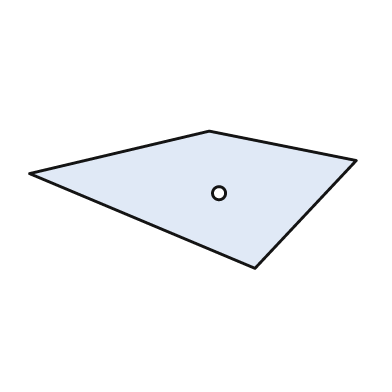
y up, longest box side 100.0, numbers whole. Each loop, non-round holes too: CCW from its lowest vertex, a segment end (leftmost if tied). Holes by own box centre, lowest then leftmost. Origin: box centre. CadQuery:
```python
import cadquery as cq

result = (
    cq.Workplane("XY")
    .moveTo(19.0, -21.0)
    .lineTo(50.0, 12.0)
    .lineTo(5.0, 21.0)
    .lineTo(-50.0, 8.0)
    .close()
    .moveTo(8.0, 2.0)
    .circle(2.0)
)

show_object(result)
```